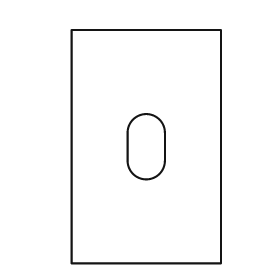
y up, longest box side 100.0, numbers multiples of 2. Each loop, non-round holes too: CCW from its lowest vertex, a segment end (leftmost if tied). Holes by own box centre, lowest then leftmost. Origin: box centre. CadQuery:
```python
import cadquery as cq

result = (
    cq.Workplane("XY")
    .moveTo(-32.0, -50.0)
    .lineTo(32.0, -50.0)
    .lineTo(32.0, 50.0)
    .lineTo(-32.0, 50.0)
    .close()
    .moveTo(-8.0, -6.0)
    .threePointArc((0.0, -14.0), (8.0, -6.0))
    .lineTo(8.0, 6.0)
    .threePointArc((0.0, 14.0), (-8.0, 6.0))
    .close()
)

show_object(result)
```